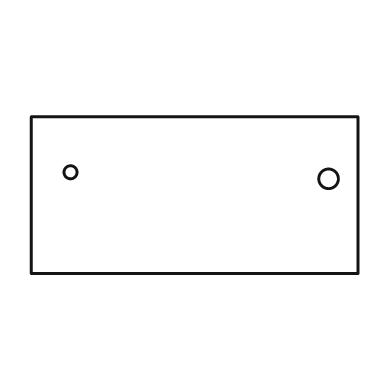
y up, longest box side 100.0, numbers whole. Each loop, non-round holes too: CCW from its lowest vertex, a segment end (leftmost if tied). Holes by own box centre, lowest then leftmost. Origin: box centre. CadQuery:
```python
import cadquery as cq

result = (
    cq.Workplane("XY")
    .moveTo(-50.0, -24.0)
    .lineTo(50.0, -24.0)
    .lineTo(50.0, 24.0)
    .lineTo(-50.0, 24.0)
    .close()
    .moveTo(41.0, 5.0)
    .circle(3.0)
    .moveTo(-38.0, 7.0)
    .circle(2.0)
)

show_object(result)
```